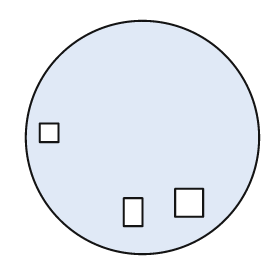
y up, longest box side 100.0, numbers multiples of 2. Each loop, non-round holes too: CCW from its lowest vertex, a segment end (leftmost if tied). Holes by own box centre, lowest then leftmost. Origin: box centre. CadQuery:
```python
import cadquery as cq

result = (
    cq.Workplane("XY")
    .moveTo(0.0, 0.0)
    .circle(50.0)
    .moveTo(-8.0, -38.0)
    .lineTo(0.0, -38.0)
    .lineTo(0.0, -26.0)
    .lineTo(-8.0, -26.0)
    .close()
    .moveTo(14.0, -34.0)
    .lineTo(26.0, -34.0)
    .lineTo(26.0, -22.0)
    .lineTo(14.0, -22.0)
    .close()
    .moveTo(-44.0, -2.0)
    .lineTo(-36.0, -2.0)
    .lineTo(-36.0, 6.0)
    .lineTo(-44.0, 6.0)
    .close()
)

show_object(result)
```